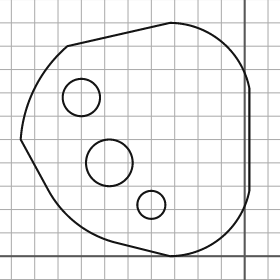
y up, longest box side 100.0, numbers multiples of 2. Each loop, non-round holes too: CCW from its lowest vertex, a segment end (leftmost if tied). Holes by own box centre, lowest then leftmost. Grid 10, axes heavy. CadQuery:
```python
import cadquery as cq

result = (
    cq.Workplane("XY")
    .moveTo(-32.0, 0.0)
    .threePointArc((-10.0, 8.0), (2.0, 28.0))
    .lineTo(2.0, 72.0)
    .threePointArc((-10.0, 92.0), (-32.0, 100.0))
    .lineTo(-76.0, 90.0)
    .threePointArc((-90.0, 72.0), (-96.0, 50.0))
    .lineTo(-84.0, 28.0)
    .threePointArc((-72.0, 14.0), (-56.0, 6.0))
    .close()
    .moveTo(-40.0, 22.0)
    .circle(6.0)
    .moveTo(-58.0, 40.0)
    .circle(10.0)
    .moveTo(-70.0, 68.0)
    .circle(8.0)
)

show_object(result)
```